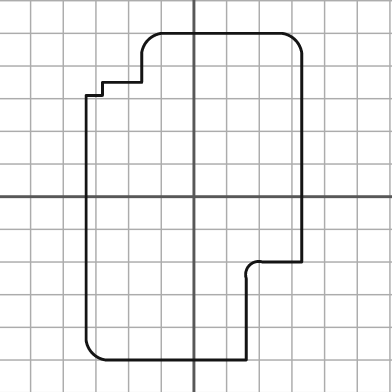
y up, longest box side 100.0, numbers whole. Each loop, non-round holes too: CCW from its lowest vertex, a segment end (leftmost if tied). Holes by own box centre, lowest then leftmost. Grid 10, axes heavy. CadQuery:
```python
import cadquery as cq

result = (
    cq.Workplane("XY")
    .moveTo(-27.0, -50.0)
    .lineTo(16.0, -50.0)
    .lineTo(16.0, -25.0)
    .threePointArc((17.0, -21.0), (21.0, -20.0))
    .lineTo(33.0, -20.0)
    .lineTo(33.0, 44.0)
    .threePointArc((31.0, 48.0), (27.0, 50.0))
    .lineTo(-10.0, 50.0)
    .threePointArc((-14.0, 48.0), (-16.0, 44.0))
    .lineTo(-16.0, 35.0)
    .lineTo(-28.0, 35.0)
    .lineTo(-28.0, 31.0)
    .lineTo(-33.0, 31.0)
    .lineTo(-33.0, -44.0)
    .threePointArc((-31.0, -48.0), (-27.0, -50.0))
    .close()
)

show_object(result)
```